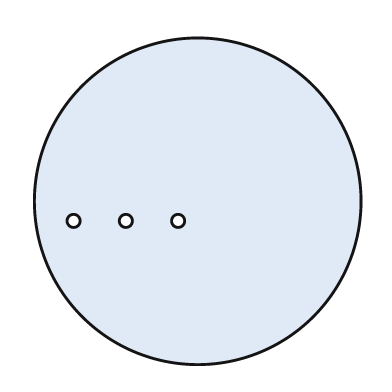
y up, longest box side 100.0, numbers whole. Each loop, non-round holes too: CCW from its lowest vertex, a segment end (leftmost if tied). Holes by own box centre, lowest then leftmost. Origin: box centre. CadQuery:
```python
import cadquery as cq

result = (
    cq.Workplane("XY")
    .moveTo(0.0, 0.0)
    .circle(50.0)
    .moveTo(-38.0, -6.0)
    .circle(2.0)
    .moveTo(-22.0, -6.0)
    .circle(2.0)
    .moveTo(-6.0, -6.0)
    .circle(2.0)
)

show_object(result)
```